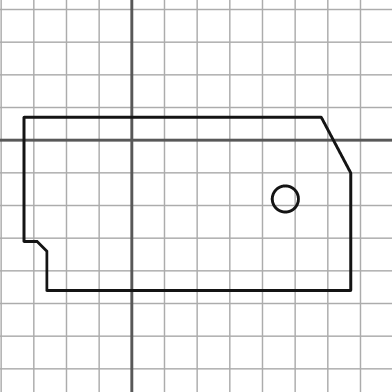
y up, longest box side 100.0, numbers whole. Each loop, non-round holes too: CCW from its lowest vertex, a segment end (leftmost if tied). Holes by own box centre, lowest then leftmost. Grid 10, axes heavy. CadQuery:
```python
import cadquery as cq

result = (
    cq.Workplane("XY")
    .moveTo(-26.0, -46.0)
    .lineTo(67.0, -46.0)
    .lineTo(67.0, -10.0)
    .lineTo(58.0, 7.0)
    .lineTo(-33.0, 7.0)
    .lineTo(-33.0, -31.0)
    .lineTo(-29.0, -31.0)
    .lineTo(-26.0, -34.0)
    .close()
    .moveTo(47.0, -18.0)
    .circle(4.0)
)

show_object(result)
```